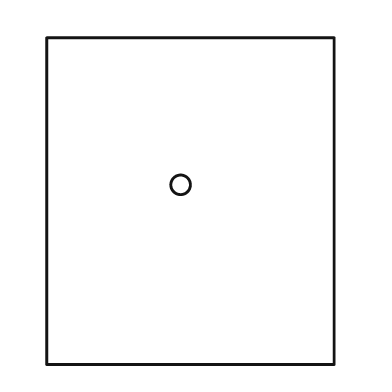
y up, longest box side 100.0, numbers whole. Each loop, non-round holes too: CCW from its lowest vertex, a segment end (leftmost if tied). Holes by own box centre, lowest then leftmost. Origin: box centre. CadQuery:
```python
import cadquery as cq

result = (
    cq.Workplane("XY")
    .moveTo(-44.0, -50.0)
    .lineTo(44.0, -50.0)
    .lineTo(44.0, 50.0)
    .lineTo(-44.0, 50.0)
    .close()
    .moveTo(-3.0, 5.0)
    .circle(3.0)
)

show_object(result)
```